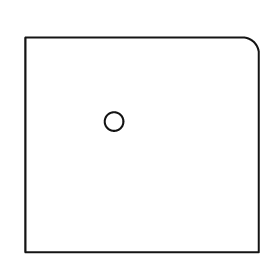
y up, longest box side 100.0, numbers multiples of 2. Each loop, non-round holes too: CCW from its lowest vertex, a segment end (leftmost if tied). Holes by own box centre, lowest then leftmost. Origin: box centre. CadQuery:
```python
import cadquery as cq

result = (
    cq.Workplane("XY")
    .moveTo(-50.0, -46.0)
    .lineTo(50.0, -46.0)
    .lineTo(50.0, 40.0)
    .threePointArc((48.0, 44.0), (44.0, 46.0))
    .lineTo(-50.0, 46.0)
    .close()
    .moveTo(-12.0, 10.0)
    .circle(4.0)
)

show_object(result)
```